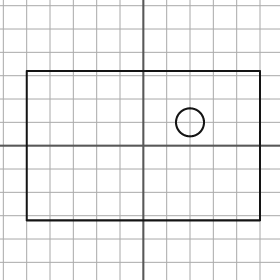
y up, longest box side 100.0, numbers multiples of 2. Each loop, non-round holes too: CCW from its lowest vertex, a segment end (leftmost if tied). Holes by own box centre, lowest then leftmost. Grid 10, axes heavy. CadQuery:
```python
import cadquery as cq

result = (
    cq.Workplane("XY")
    .moveTo(-50.0, -32.0)
    .lineTo(50.0, -32.0)
    .lineTo(50.0, 32.0)
    .lineTo(-50.0, 32.0)
    .close()
    .moveTo(20.0, 10.0)
    .circle(6.0)
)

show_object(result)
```